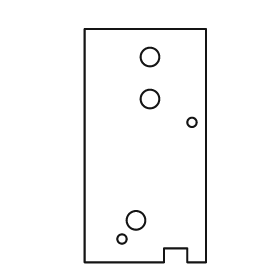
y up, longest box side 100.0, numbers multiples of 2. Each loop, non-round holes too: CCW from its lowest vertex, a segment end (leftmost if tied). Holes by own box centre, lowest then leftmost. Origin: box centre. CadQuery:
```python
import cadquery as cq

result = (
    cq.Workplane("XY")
    .moveTo(-26.0, -50.0)
    .lineTo(8.0, -50.0)
    .lineTo(8.0, -44.0)
    .lineTo(18.0, -44.0)
    .lineTo(18.0, -50.0)
    .lineTo(26.0, -50.0)
    .lineTo(26.0, 50.0)
    .lineTo(-26.0, 50.0)
    .close()
    .moveTo(-10.0, -40.0)
    .circle(2.0)
    .moveTo(-4.0, -32.0)
    .circle(4.0)
    .moveTo(20.0, 10.0)
    .circle(2.0)
    .moveTo(2.0, 20.0)
    .circle(4.0)
    .moveTo(2.0, 38.0)
    .circle(4.0)
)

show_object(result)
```